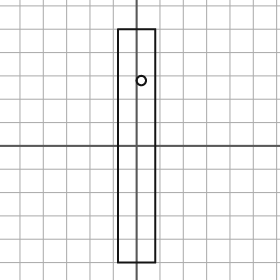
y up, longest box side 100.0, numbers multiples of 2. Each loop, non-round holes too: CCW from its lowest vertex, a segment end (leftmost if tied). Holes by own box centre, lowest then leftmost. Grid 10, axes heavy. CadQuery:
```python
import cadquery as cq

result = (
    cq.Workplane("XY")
    .moveTo(-8.0, -50.0)
    .lineTo(8.0, -50.0)
    .lineTo(8.0, 50.0)
    .lineTo(-8.0, 50.0)
    .close()
    .moveTo(2.0, 28.0)
    .circle(2.0)
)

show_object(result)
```